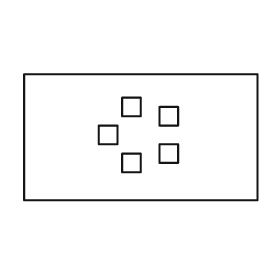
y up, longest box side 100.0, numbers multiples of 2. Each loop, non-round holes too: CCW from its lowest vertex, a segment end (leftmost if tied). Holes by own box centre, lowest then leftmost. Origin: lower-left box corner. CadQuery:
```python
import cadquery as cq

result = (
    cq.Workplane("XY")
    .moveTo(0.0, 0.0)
    .lineTo(100.0, 0.0)
    .lineTo(100.0, 54.0)
    .lineTo(0.0, 54.0)
    .close()
    .moveTo(42.0, 12.0)
    .lineTo(50.0, 12.0)
    .lineTo(50.0, 20.0)
    .lineTo(42.0, 20.0)
    .close()
    .moveTo(58.0, 16.0)
    .lineTo(66.0, 16.0)
    .lineTo(66.0, 24.0)
    .lineTo(58.0, 24.0)
    .close()
    .moveTo(32.0, 24.0)
    .lineTo(40.0, 24.0)
    .lineTo(40.0, 32.0)
    .lineTo(32.0, 32.0)
    .close()
    .moveTo(58.0, 32.0)
    .lineTo(66.0, 32.0)
    .lineTo(66.0, 40.0)
    .lineTo(58.0, 40.0)
    .close()
    .moveTo(42.0, 36.0)
    .lineTo(50.0, 36.0)
    .lineTo(50.0, 44.0)
    .lineTo(42.0, 44.0)
    .close()
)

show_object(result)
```